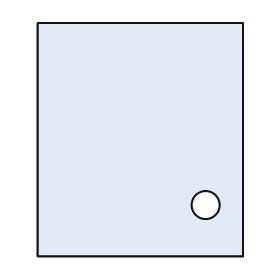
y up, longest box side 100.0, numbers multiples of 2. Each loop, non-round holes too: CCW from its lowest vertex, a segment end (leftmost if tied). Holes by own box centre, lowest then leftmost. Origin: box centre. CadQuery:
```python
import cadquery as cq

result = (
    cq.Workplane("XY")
    .moveTo(-44.0, -50.0)
    .lineTo(44.0, -50.0)
    .lineTo(44.0, 50.0)
    .lineTo(-44.0, 50.0)
    .close()
    .moveTo(28.0, -28.0)
    .circle(6.0)
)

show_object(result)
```